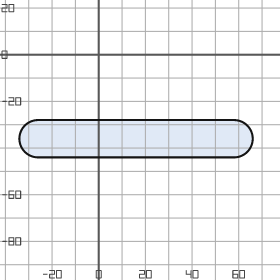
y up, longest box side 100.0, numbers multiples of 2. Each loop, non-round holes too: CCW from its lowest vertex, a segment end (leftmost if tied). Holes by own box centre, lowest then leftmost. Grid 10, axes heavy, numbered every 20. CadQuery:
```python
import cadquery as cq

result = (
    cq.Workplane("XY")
    .moveTo(-26.0, -44.0)
    .lineTo(58.0, -44.0)
    .threePointArc((66.0, -36.0), (58.0, -28.0))
    .lineTo(-26.0, -28.0)
    .threePointArc((-34.0, -36.0), (-26.0, -44.0))
    .close()
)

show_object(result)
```